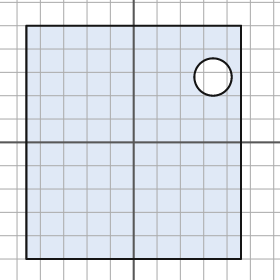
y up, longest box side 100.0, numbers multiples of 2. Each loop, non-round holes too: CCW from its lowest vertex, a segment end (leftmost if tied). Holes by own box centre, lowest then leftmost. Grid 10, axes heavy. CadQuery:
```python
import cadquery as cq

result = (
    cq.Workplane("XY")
    .moveTo(-46.0, -50.0)
    .lineTo(46.0, -50.0)
    .lineTo(46.0, 50.0)
    .lineTo(-46.0, 50.0)
    .close()
    .moveTo(34.0, 28.0)
    .circle(8.0)
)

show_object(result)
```